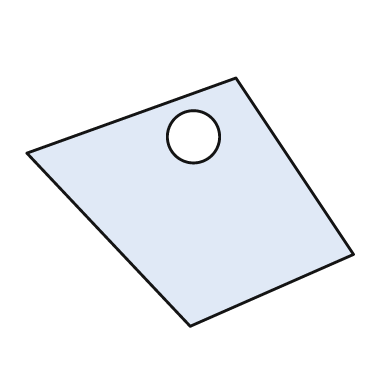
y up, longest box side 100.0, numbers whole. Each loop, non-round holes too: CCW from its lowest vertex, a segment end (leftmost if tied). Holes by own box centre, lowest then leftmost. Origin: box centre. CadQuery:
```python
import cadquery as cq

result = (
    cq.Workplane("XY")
    .moveTo(0.0, -38.0)
    .lineTo(50.0, -16.0)
    .lineTo(14.0, 38.0)
    .lineTo(-50.0, 15.0)
    .close()
    .moveTo(1.0, 20.0)
    .circle(8.0)
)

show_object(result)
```